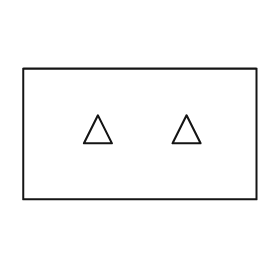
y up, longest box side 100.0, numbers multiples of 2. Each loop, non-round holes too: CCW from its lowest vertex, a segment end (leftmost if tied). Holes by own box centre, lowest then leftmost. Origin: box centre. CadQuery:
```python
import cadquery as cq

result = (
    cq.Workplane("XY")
    .moveTo(-50.0, -28.0)
    .lineTo(50.0, -28.0)
    .lineTo(50.0, 28.0)
    .lineTo(-50.0, 28.0)
    .close()
    .moveTo(-24.0, -4.0)
    .lineTo(-12.0, -4.0)
    .lineTo(-18.0, 8.0)
    .close()
    .moveTo(14.0, -4.0)
    .lineTo(26.0, -4.0)
    .lineTo(20.0, 8.0)
    .close()
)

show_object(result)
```